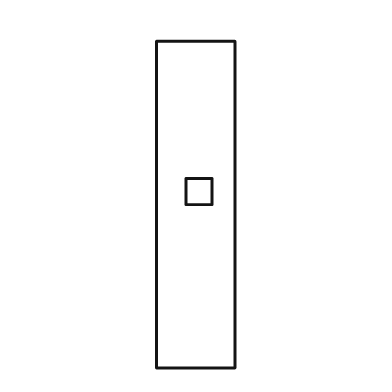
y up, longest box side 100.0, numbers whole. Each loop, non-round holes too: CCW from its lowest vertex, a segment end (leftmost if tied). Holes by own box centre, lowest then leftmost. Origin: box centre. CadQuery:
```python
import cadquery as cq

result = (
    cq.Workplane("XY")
    .moveTo(-12.0, -50.0)
    .lineTo(12.0, -50.0)
    .lineTo(12.0, 50.0)
    .lineTo(-12.0, 50.0)
    .close()
    .moveTo(-3.0, 0.0)
    .lineTo(5.0, 0.0)
    .lineTo(5.0, 8.0)
    .lineTo(-3.0, 8.0)
    .close()
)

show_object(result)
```